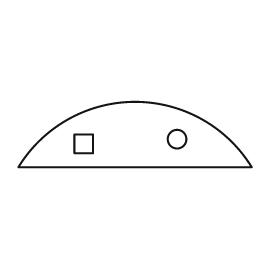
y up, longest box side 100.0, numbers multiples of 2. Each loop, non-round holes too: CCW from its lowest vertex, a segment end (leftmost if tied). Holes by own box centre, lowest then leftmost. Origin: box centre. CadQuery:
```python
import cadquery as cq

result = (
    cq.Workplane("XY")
    .moveTo(-50.0, -14.0)
    .lineTo(50.0, -14.0)
    .threePointArc((0.0, 14.0), (-50.0, -14.0))
    .close()
    .moveTo(-26.0, -8.0)
    .lineTo(-18.0, -8.0)
    .lineTo(-18.0, 0.0)
    .lineTo(-26.0, 0.0)
    .close()
    .moveTo(18.0, -2.0)
    .circle(4.0)
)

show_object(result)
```